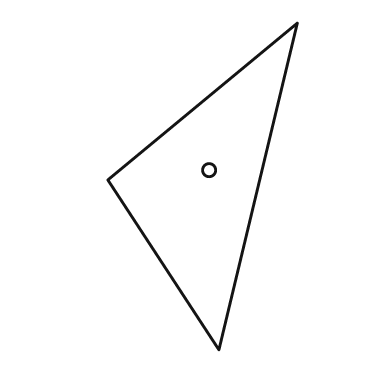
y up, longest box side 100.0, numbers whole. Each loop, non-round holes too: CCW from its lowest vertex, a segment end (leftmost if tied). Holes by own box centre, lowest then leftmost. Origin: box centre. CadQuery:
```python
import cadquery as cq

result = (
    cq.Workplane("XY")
    .moveTo(5.0, -50.0)
    .lineTo(29.0, 50.0)
    .lineTo(-29.0, 2.0)
    .close()
    .moveTo(2.0, 5.0)
    .circle(2.0)
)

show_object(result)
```